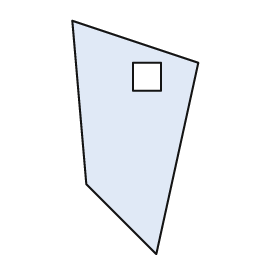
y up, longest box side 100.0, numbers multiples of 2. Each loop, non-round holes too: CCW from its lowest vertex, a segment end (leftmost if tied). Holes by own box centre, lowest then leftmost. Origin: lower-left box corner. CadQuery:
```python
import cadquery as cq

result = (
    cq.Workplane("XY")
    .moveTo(36.0, 0.0)
    .lineTo(54.0, 82.0)
    .lineTo(0.0, 100.0)
    .lineTo(6.0, 30.0)
    .close()
    .moveTo(26.0, 70.0)
    .lineTo(38.0, 70.0)
    .lineTo(38.0, 82.0)
    .lineTo(26.0, 82.0)
    .close()
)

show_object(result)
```